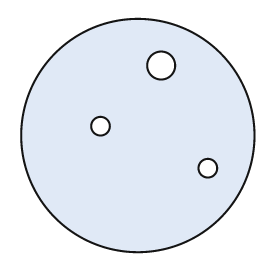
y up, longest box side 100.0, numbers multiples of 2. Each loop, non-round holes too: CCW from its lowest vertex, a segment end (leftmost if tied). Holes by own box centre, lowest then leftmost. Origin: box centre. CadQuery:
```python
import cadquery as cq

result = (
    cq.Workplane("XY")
    .moveTo(0.0, 0.0)
    .circle(50.0)
    .moveTo(30.0, -14.0)
    .circle(4.0)
    .moveTo(-16.0, 4.0)
    .circle(4.0)
    .moveTo(10.0, 30.0)
    .circle(6.0)
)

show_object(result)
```